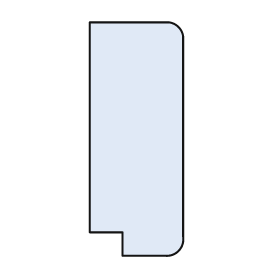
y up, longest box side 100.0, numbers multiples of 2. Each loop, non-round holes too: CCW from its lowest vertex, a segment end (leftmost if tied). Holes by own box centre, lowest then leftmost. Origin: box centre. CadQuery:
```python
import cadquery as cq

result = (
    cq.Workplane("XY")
    .moveTo(-6.0, -50.0)
    .lineTo(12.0, -50.0)
    .threePointArc((18.0, -48.0), (20.0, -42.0))
    .lineTo(20.0, 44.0)
    .threePointArc((18.0, 48.0), (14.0, 50.0))
    .lineTo(-20.0, 50.0)
    .lineTo(-20.0, -40.0)
    .lineTo(-6.0, -40.0)
    .close()
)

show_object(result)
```